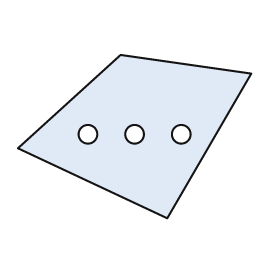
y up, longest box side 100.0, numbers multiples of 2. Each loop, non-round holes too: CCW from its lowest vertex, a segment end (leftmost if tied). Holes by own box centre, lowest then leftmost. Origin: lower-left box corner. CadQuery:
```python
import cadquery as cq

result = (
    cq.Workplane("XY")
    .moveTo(64.0, 0.0)
    .lineTo(100.0, 62.0)
    .lineTo(44.0, 70.0)
    .lineTo(0.0, 30.0)
    .close()
    .moveTo(30.0, 36.0)
    .circle(4.0)
    .moveTo(50.0, 36.0)
    .circle(4.0)
    .moveTo(70.0, 36.0)
    .circle(4.0)
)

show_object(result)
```